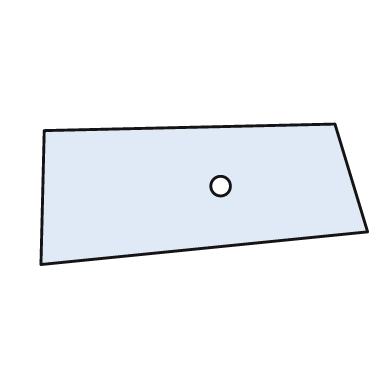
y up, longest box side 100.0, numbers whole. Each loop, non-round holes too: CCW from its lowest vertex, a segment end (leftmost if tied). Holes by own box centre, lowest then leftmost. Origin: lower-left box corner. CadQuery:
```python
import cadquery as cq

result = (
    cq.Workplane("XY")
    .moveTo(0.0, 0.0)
    .lineTo(100.0, 10.0)
    .lineTo(90.0, 43.0)
    .lineTo(1.0, 41.0)
    .close()
    .moveTo(55.0, 24.0)
    .circle(3.0)
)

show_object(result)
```